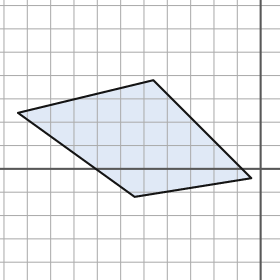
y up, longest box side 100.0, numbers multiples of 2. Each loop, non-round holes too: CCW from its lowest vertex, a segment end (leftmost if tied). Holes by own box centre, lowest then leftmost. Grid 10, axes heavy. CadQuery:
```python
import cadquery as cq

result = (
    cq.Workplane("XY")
    .moveTo(-54.0, -12.0)
    .lineTo(-4.0, -4.0)
    .lineTo(-46.0, 38.0)
    .lineTo(-104.0, 24.0)
    .close()
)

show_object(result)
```